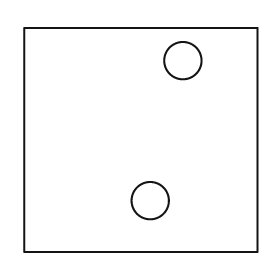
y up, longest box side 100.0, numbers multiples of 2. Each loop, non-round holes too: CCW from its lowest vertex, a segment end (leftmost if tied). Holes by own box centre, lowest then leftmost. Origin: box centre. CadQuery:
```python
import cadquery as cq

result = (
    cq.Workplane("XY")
    .moveTo(-50.0, -48.0)
    .lineTo(50.0, -48.0)
    .lineTo(50.0, 48.0)
    .lineTo(-50.0, 48.0)
    .close()
    .moveTo(4.0, -26.0)
    .circle(8.0)
    .moveTo(18.0, 34.0)
    .circle(8.0)
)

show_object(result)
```